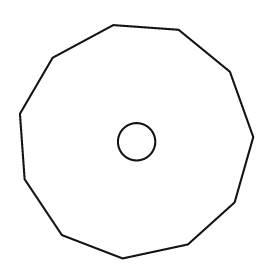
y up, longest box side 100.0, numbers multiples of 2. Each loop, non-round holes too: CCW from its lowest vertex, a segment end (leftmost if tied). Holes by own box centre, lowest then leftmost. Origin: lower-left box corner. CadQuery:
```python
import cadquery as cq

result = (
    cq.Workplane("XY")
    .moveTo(44.0, 0.0)
    .lineTo(72.0, 6.0)
    .lineTo(92.0, 24.0)
    .lineTo(100.0, 52.0)
    .lineTo(90.0, 80.0)
    .lineTo(68.0, 98.0)
    .lineTo(40.0, 100.0)
    .lineTo(14.0, 86.0)
    .lineTo(0.0, 62.0)
    .lineTo(2.0, 34.0)
    .lineTo(18.0, 10.0)
    .close()
    .moveTo(50.0, 50.0)
    .circle(8.0)
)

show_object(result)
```